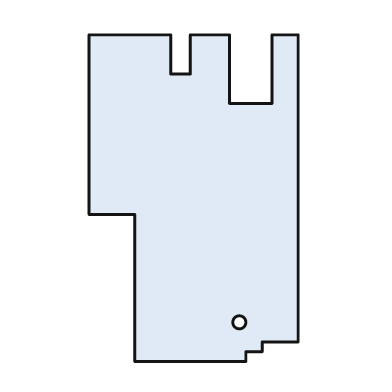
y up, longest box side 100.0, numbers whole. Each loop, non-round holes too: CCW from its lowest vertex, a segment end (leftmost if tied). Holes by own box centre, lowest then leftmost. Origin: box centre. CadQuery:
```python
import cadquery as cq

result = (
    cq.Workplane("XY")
    .moveTo(-18.0, -50.0)
    .lineTo(16.0, -50.0)
    .lineTo(16.0, -47.0)
    .lineTo(21.0, -47.0)
    .lineTo(21.0, -44.0)
    .lineTo(32.0, -44.0)
    .lineTo(32.0, 50.0)
    .lineTo(24.0, 50.0)
    .lineTo(24.0, 29.0)
    .lineTo(11.0, 29.0)
    .lineTo(11.0, 50.0)
    .lineTo(-1.0, 50.0)
    .lineTo(-1.0, 38.0)
    .lineTo(-7.0, 38.0)
    .lineTo(-7.0, 50.0)
    .lineTo(-32.0, 50.0)
    .lineTo(-32.0, -5.0)
    .lineTo(-18.0, -5.0)
    .close()
    .moveTo(14.0, -38.0)
    .circle(2.0)
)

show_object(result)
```